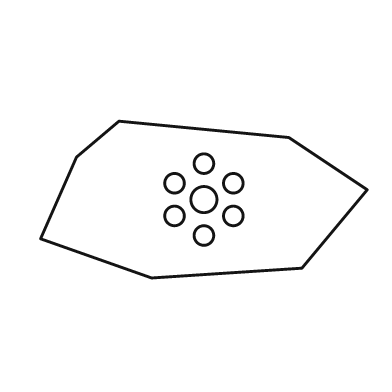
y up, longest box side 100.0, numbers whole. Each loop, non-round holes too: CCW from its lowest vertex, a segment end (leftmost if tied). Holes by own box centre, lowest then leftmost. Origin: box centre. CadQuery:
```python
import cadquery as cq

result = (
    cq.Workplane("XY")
    .moveTo(-16.0, -24.0)
    .lineTo(30.0, -21.0)
    .lineTo(50.0, 3.0)
    .lineTo(26.0, 19.0)
    .lineTo(-26.0, 24.0)
    .lineTo(-39.0, 13.0)
    .lineTo(-50.0, -12.0)
    .close()
    .moveTo(0.0, -11.0)
    .circle(3.0)
    .moveTo(-9.0, -5.0)
    .circle(3.0)
    .moveTo(9.0, -5.0)
    .circle(3.0)
    .moveTo(0.0, 0.0)
    .circle(4.0)
    .moveTo(-9.0, 5.0)
    .circle(3.0)
    .moveTo(9.0, 5.0)
    .circle(3.0)
    .moveTo(0.0, 11.0)
    .circle(3.0)
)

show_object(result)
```